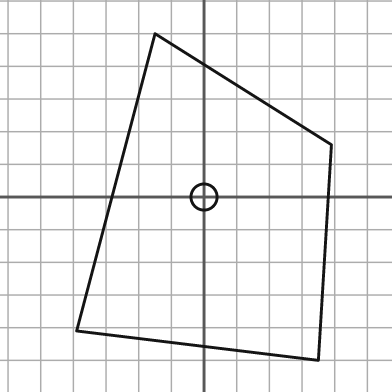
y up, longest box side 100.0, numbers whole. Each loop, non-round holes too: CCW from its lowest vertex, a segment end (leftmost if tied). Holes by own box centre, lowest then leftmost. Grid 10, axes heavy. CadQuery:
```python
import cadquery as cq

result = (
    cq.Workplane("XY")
    .moveTo(35.0, -50.0)
    .lineTo(39.0, 16.0)
    .lineTo(-15.0, 50.0)
    .lineTo(-39.0, -41.0)
    .close()
    .moveTo(0.0, 0.0)
    .circle(4.0)
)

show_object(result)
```